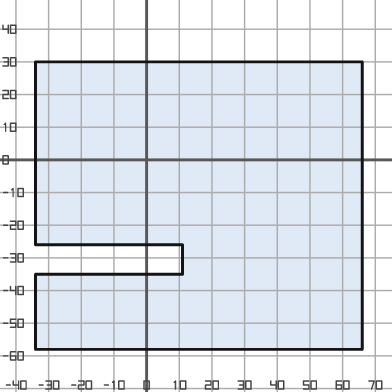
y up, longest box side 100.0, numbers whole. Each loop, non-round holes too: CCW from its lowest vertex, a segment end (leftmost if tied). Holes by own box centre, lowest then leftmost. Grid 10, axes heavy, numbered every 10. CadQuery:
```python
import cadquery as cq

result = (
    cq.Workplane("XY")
    .moveTo(-34.0, -58.0)
    .lineTo(66.0, -58.0)
    .lineTo(66.0, 30.0)
    .lineTo(-34.0, 30.0)
    .lineTo(-34.0, -26.0)
    .lineTo(11.0, -26.0)
    .lineTo(11.0, -35.0)
    .lineTo(-34.0, -35.0)
    .close()
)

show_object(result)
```